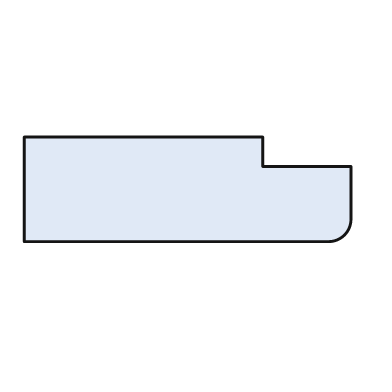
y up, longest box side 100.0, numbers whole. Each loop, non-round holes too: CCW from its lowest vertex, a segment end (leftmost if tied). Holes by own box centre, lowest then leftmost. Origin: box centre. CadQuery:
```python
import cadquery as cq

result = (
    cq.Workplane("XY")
    .moveTo(-50.0, -16.0)
    .lineTo(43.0, -16.0)
    .threePointArc((48.0, -14.0), (50.0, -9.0))
    .lineTo(50.0, 7.0)
    .lineTo(23.0, 7.0)
    .lineTo(23.0, 16.0)
    .lineTo(-50.0, 16.0)
    .close()
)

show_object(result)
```